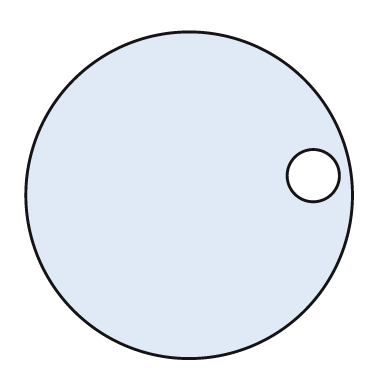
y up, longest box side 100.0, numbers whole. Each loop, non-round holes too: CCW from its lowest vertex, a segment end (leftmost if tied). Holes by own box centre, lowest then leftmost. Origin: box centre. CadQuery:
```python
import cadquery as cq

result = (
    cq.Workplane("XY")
    .moveTo(0.0, 0.0)
    .circle(50.0)
    .moveTo(38.0, 6.0)
    .circle(8.0)
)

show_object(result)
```